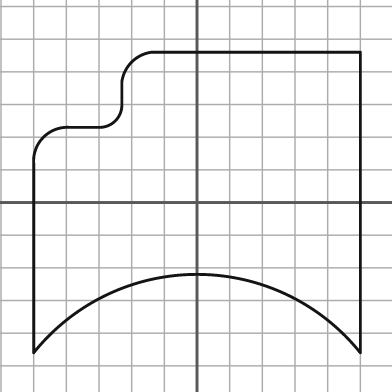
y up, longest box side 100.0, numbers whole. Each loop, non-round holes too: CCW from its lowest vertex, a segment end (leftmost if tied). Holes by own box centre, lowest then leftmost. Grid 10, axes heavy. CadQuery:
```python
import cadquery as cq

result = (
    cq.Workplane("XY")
    .moveTo(-50.0, -46.0)
    .threePointArc((0.0, -22.0), (50.0, -46.0))
    .lineTo(50.0, 46.0)
    .lineTo(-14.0, 46.0)
    .threePointArc((-20.0, 43.0), (-23.0, 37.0))
    .lineTo(-23.0, 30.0)
    .threePointArc((-25.0, 25.0), (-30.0, 23.0))
    .lineTo(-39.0, 23.0)
    .threePointArc((-47.0, 20.0), (-50.0, 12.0))
    .close()
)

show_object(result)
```